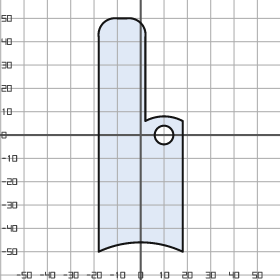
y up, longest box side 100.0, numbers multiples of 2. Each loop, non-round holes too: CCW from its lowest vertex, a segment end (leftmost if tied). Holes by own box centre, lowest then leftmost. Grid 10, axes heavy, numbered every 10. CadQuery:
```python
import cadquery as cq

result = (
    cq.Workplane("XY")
    .moveTo(-18.0, -50.0)
    .threePointArc((0.0, -46.0), (18.0, -50.0))
    .lineTo(18.0, 6.0)
    .threePointArc((10.0, 8.0), (2.0, 6.0))
    .lineTo(2.0, 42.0)
    .threePointArc((0.0, 48.0), (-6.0, 50.0))
    .lineTo(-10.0, 50.0)
    .threePointArc((-16.0, 48.0), (-18.0, 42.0))
    .close()
    .moveTo(10.0, 0.0)
    .circle(4.0)
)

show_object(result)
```